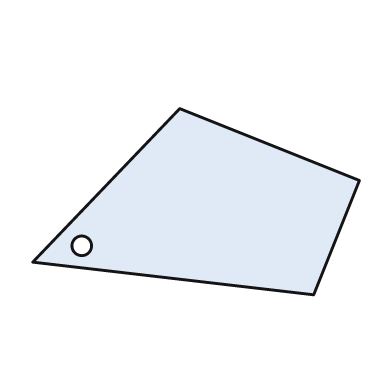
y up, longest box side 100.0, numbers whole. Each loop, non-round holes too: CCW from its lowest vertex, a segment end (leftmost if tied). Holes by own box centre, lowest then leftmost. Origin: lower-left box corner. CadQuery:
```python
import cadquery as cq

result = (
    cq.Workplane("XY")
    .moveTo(86.0, 0.0)
    .lineTo(100.0, 35.0)
    .lineTo(45.0, 57.0)
    .lineTo(0.0, 10.0)
    .close()
    .moveTo(15.0, 15.0)
    .circle(3.0)
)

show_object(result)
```